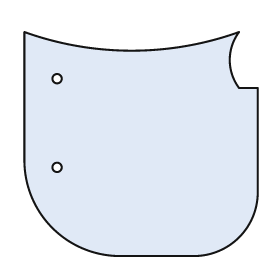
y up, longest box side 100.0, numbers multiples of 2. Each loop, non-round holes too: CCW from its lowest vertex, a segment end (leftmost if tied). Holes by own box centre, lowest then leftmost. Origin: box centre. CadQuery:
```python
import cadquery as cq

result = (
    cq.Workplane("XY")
    .moveTo(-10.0, -48.0)
    .lineTo(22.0, -48.0)
    .threePointArc((42.0, -40.0), (50.0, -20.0))
    .lineTo(50.0, 24.0)
    .lineTo(42.0, 24.0)
    .threePointArc((38.0, 36.0), (42.0, 48.0))
    .threePointArc((-4.0, 40.0), (-50.0, 48.0))
    .lineTo(-50.0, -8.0)
    .threePointArc((-38.0, -36.0), (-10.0, -48.0))
    .close()
    .moveTo(-36.0, -10.0)
    .circle(2.0)
    .moveTo(-36.0, 28.0)
    .circle(2.0)
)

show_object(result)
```